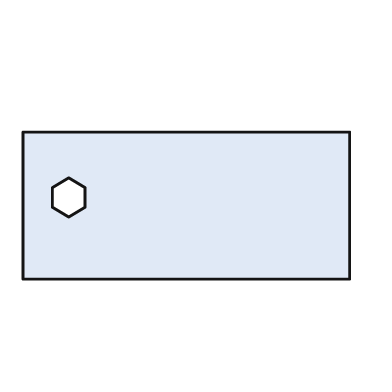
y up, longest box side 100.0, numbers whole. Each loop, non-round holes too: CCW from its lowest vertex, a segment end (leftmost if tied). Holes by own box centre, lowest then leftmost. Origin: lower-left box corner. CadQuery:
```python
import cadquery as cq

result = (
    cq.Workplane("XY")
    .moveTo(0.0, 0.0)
    .lineTo(100.0, 0.0)
    .lineTo(100.0, 45.0)
    .lineTo(0.0, 45.0)
    .close()
    .moveTo(14.0, 19.0)
    .lineTo(19.0, 22.0)
    .lineTo(19.0, 28.0)
    .lineTo(14.0, 31.0)
    .lineTo(9.0, 28.0)
    .lineTo(9.0, 22.0)
    .close()
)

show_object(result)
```